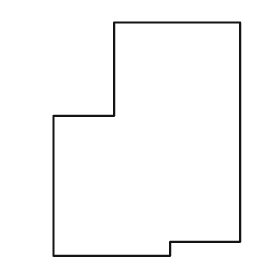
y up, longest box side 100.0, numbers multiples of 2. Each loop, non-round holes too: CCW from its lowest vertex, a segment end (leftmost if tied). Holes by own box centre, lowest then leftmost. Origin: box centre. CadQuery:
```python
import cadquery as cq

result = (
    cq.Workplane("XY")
    .moveTo(-40.0, -50.0)
    .lineTo(10.0, -50.0)
    .lineTo(10.0, -44.0)
    .lineTo(40.0, -44.0)
    .lineTo(40.0, 50.0)
    .lineTo(-14.0, 50.0)
    .lineTo(-14.0, 10.0)
    .lineTo(-40.0, 10.0)
    .close()
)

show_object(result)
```